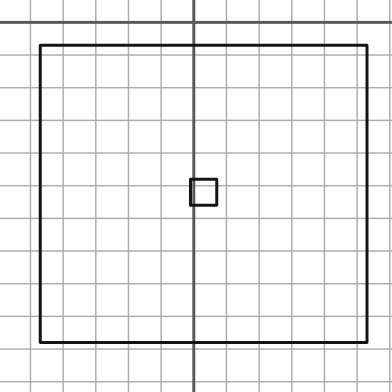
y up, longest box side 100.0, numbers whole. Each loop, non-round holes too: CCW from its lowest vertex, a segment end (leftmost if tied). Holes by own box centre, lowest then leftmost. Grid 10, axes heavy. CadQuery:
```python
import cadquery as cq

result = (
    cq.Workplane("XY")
    .moveTo(-47.0, -98.0)
    .lineTo(53.0, -98.0)
    .lineTo(53.0, -7.0)
    .lineTo(-47.0, -7.0)
    .close()
    .moveTo(-1.0, -56.0)
    .lineTo(7.0, -56.0)
    .lineTo(7.0, -48.0)
    .lineTo(-1.0, -48.0)
    .close()
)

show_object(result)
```